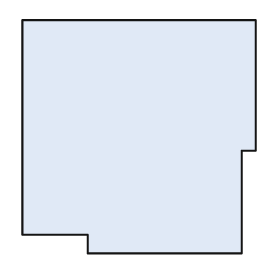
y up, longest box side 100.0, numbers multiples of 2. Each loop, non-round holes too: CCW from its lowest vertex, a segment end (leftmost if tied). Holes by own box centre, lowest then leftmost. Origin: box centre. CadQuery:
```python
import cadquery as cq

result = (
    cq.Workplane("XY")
    .moveTo(-22.0, -50.0)
    .lineTo(44.0, -50.0)
    .lineTo(44.0, -6.0)
    .lineTo(50.0, -6.0)
    .lineTo(50.0, 50.0)
    .lineTo(-50.0, 50.0)
    .lineTo(-50.0, -42.0)
    .lineTo(-22.0, -42.0)
    .close()
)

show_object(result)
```